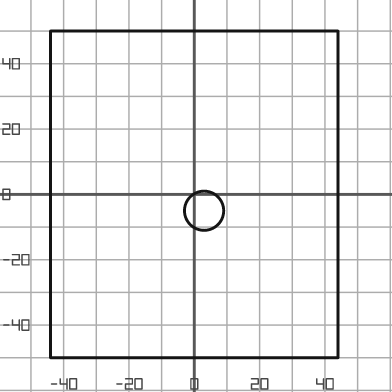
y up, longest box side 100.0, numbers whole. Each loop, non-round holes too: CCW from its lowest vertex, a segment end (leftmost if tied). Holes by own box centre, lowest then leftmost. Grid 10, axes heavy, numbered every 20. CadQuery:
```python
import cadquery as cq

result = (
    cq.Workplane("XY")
    .moveTo(-44.0, -50.0)
    .lineTo(44.0, -50.0)
    .lineTo(44.0, 50.0)
    .lineTo(-44.0, 50.0)
    .close()
    .moveTo(3.0, -5.0)
    .circle(6.0)
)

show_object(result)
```